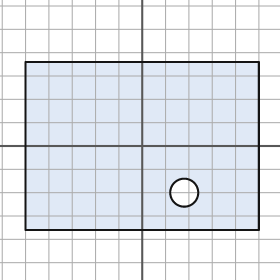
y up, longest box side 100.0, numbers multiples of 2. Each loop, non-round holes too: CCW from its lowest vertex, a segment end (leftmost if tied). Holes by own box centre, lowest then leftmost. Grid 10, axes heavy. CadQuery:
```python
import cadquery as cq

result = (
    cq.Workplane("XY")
    .moveTo(-50.0, -36.0)
    .lineTo(50.0, -36.0)
    .lineTo(50.0, 36.0)
    .lineTo(-50.0, 36.0)
    .close()
    .moveTo(18.0, -20.0)
    .circle(6.0)
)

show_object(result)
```